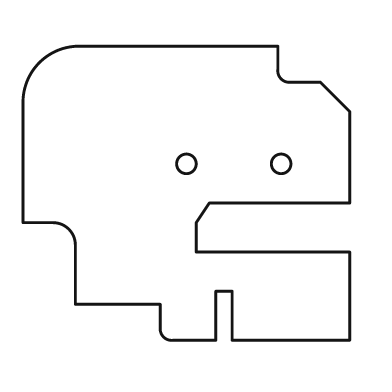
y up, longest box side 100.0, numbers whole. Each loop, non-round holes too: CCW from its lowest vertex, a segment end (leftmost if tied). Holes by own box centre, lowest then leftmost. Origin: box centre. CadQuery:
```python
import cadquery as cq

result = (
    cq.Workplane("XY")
    .moveTo(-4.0, -45.0)
    .lineTo(9.0, -45.0)
    .lineTo(9.0, -30.0)
    .lineTo(14.0, -30.0)
    .lineTo(14.0, -45.0)
    .lineTo(50.0, -45.0)
    .lineTo(50.0, -18.0)
    .lineTo(3.0, -18.0)
    .lineTo(3.0, -9.0)
    .lineTo(7.0, -3.0)
    .lineTo(50.0, -3.0)
    .lineTo(50.0, 25.0)
    .lineTo(41.0, 34.0)
    .lineTo(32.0, 34.0)
    .threePointArc((29.0, 35.0), (28.0, 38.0))
    .lineTo(28.0, 45.0)
    .lineTo(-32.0, 45.0)
    .threePointArc((-45.0, 40.0), (-50.0, 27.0))
    .lineTo(-50.0, -9.0)
    .lineTo(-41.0, -9.0)
    .threePointArc((-36.0, -11.0), (-34.0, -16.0))
    .lineTo(-34.0, -34.0)
    .lineTo(-8.0, -34.0)
    .lineTo(-8.0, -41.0)
    .threePointArc((-7.0, -44.0), (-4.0, -45.0))
    .close()
    .moveTo(0.0, 9.0)
    .circle(3.0)
    .moveTo(29.0, 9.0)
    .circle(3.0)
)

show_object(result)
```